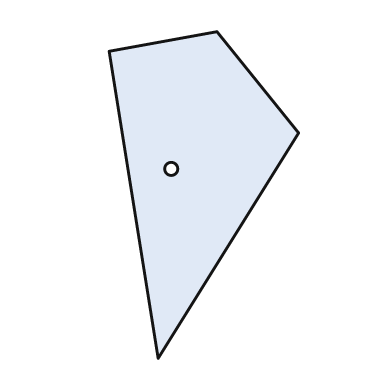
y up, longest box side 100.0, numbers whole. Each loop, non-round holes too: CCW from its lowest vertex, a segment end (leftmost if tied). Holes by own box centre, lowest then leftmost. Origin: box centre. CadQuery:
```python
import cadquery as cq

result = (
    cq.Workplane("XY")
    .moveTo(-14.0, -50.0)
    .lineTo(29.0, 19.0)
    .lineTo(4.0, 50.0)
    .lineTo(-29.0, 44.0)
    .close()
    .moveTo(-10.0, 8.0)
    .circle(2.0)
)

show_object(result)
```